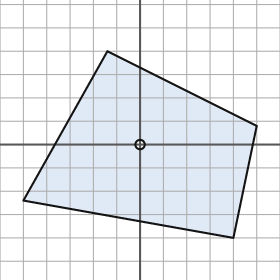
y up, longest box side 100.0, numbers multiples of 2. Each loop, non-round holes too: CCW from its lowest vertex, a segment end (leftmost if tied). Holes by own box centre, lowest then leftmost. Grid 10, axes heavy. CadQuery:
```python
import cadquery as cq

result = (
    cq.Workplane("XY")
    .moveTo(40.0, -40.0)
    .lineTo(50.0, 8.0)
    .lineTo(-14.0, 40.0)
    .lineTo(-50.0, -24.0)
    .close()
    .moveTo(0.0, 0.0)
    .circle(2.0)
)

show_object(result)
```